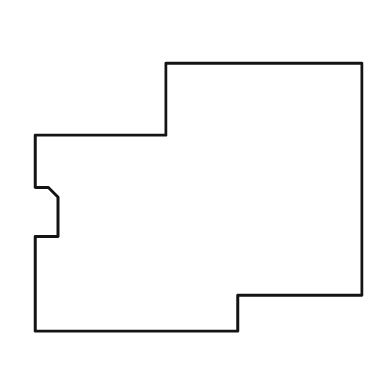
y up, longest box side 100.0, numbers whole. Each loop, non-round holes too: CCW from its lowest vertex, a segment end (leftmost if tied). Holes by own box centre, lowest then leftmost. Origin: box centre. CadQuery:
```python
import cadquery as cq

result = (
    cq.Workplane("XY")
    .moveTo(-50.0, -41.0)
    .lineTo(12.0, -41.0)
    .lineTo(12.0, -30.0)
    .lineTo(50.0, -30.0)
    .lineTo(50.0, 41.0)
    .lineTo(-10.0, 41.0)
    .lineTo(-10.0, 19.0)
    .lineTo(-50.0, 19.0)
    .lineTo(-50.0, 3.0)
    .lineTo(-46.0, 3.0)
    .lineTo(-43.0, 0.0)
    .lineTo(-43.0, -12.0)
    .lineTo(-50.0, -12.0)
    .close()
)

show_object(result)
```